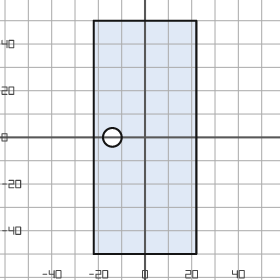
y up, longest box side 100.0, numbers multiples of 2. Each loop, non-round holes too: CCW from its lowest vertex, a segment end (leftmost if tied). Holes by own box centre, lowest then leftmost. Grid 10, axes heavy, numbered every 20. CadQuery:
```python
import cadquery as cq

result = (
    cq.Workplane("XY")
    .moveTo(-22.0, -50.0)
    .lineTo(22.0, -50.0)
    .lineTo(22.0, 50.0)
    .lineTo(-22.0, 50.0)
    .close()
    .moveTo(-14.0, 0.0)
    .circle(4.0)
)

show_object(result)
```